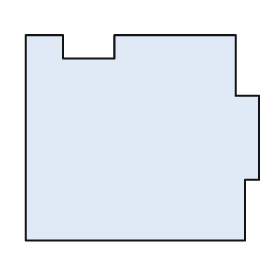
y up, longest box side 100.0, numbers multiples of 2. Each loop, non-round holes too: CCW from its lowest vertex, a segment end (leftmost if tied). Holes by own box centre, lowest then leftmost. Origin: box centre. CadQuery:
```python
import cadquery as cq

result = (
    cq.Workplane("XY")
    .moveTo(-50.0, -44.0)
    .lineTo(44.0, -44.0)
    .lineTo(44.0, -18.0)
    .lineTo(50.0, -18.0)
    .lineTo(50.0, 18.0)
    .lineTo(40.0, 18.0)
    .lineTo(40.0, 44.0)
    .lineTo(-12.0, 44.0)
    .lineTo(-12.0, 34.0)
    .lineTo(-34.0, 34.0)
    .lineTo(-34.0, 44.0)
    .lineTo(-50.0, 44.0)
    .close()
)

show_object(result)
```